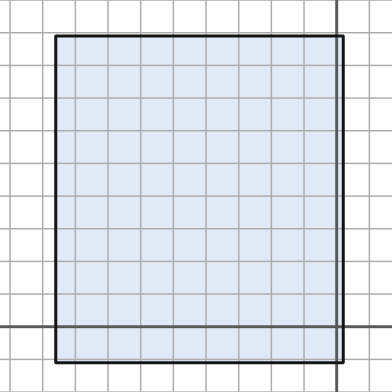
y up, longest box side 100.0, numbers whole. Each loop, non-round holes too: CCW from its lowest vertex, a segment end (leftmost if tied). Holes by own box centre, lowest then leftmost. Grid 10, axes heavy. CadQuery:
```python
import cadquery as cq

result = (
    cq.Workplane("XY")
    .moveTo(-86.0, -11.0)
    .lineTo(2.0, -11.0)
    .lineTo(2.0, 89.0)
    .lineTo(-86.0, 89.0)
    .close()
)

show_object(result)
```